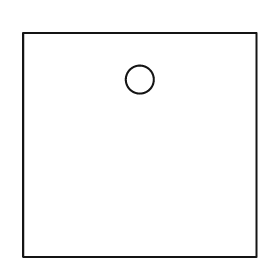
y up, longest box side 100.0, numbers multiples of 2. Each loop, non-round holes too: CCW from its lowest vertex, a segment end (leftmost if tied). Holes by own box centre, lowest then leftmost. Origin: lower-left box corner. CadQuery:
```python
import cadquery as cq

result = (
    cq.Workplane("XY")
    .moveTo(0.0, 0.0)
    .lineTo(100.0, 0.0)
    .lineTo(100.0, 96.0)
    .lineTo(0.0, 96.0)
    .close()
    .moveTo(50.0, 76.0)
    .circle(6.0)
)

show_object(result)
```